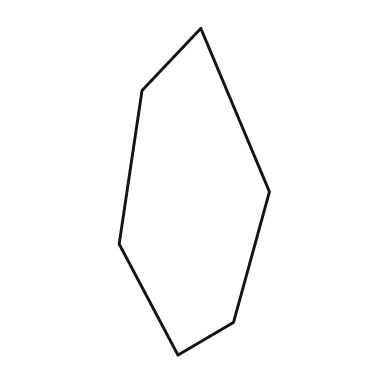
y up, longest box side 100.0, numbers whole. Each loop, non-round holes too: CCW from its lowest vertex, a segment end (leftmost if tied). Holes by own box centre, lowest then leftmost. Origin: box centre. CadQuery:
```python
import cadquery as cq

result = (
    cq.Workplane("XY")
    .moveTo(-5.0, -50.0)
    .lineTo(12.0, -40.0)
    .lineTo(23.0, 0.0)
    .lineTo(2.0, 50.0)
    .lineTo(-16.0, 31.0)
    .lineTo(-23.0, -16.0)
    .close()
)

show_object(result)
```